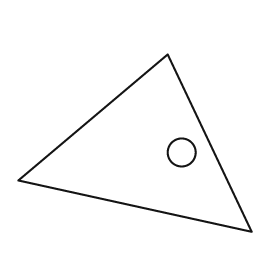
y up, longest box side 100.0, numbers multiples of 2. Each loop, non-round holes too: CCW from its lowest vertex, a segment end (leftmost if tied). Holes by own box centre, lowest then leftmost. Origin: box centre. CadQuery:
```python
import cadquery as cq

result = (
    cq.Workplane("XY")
    .moveTo(50.0, -38.0)
    .lineTo(14.0, 38.0)
    .lineTo(-50.0, -16.0)
    .close()
    .moveTo(20.0, -4.0)
    .circle(6.0)
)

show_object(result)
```